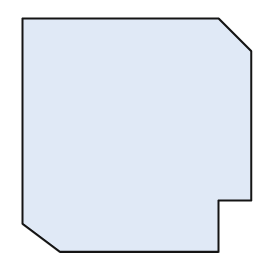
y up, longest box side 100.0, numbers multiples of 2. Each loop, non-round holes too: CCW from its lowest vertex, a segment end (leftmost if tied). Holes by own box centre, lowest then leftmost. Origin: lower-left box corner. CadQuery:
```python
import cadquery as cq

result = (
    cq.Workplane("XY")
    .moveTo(16.0, 0.0)
    .lineTo(84.0, 0.0)
    .lineTo(84.0, 22.0)
    .lineTo(98.0, 22.0)
    .lineTo(98.0, 86.0)
    .lineTo(84.0, 100.0)
    .lineTo(0.0, 100.0)
    .lineTo(0.0, 12.0)
    .close()
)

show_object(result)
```